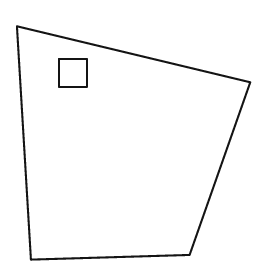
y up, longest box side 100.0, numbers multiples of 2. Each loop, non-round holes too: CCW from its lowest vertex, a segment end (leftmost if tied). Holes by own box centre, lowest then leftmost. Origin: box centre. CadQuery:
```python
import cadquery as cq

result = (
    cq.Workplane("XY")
    .moveTo(-44.0, -50.0)
    .lineTo(24.0, -48.0)
    .lineTo(50.0, 26.0)
    .lineTo(-50.0, 50.0)
    .close()
    .moveTo(-32.0, 24.0)
    .lineTo(-20.0, 24.0)
    .lineTo(-20.0, 36.0)
    .lineTo(-32.0, 36.0)
    .close()
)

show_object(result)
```